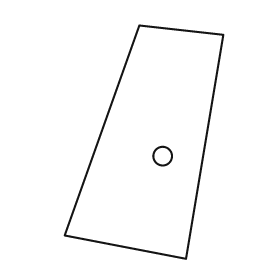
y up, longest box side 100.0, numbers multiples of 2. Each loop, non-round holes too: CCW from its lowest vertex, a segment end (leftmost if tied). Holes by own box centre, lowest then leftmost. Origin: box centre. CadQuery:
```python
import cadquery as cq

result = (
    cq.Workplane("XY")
    .moveTo(18.0, -50.0)
    .lineTo(34.0, 46.0)
    .lineTo(-2.0, 50.0)
    .lineTo(-34.0, -40.0)
    .close()
    .moveTo(8.0, -6.0)
    .circle(4.0)
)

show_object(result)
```